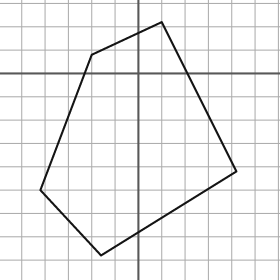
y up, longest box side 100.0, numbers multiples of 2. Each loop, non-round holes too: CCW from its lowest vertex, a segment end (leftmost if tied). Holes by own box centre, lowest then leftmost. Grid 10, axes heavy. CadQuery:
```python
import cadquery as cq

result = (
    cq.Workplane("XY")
    .moveTo(-16.0, -78.0)
    .lineTo(42.0, -42.0)
    .lineTo(10.0, 22.0)
    .lineTo(-20.0, 8.0)
    .lineTo(-42.0, -50.0)
    .close()
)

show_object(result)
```